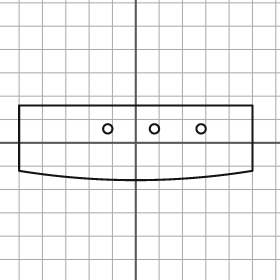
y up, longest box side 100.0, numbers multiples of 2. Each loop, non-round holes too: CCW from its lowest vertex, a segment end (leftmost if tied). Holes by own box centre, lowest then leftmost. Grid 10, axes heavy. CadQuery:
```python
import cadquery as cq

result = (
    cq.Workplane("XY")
    .moveTo(-50.0, -12.0)
    .threePointArc((0.0, -16.0), (50.0, -12.0))
    .lineTo(50.0, 16.0)
    .lineTo(-50.0, 16.0)
    .close()
    .moveTo(-12.0, 6.0)
    .circle(2.0)
    .moveTo(8.0, 6.0)
    .circle(2.0)
    .moveTo(28.0, 6.0)
    .circle(2.0)
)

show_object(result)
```